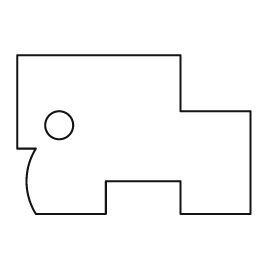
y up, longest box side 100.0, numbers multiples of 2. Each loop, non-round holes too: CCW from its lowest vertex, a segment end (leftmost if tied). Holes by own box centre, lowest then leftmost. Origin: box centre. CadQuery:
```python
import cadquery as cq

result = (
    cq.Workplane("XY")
    .moveTo(-42.0, -34.0)
    .lineTo(-12.0, -34.0)
    .lineTo(-12.0, -20.0)
    .lineTo(20.0, -20.0)
    .lineTo(20.0, -34.0)
    .lineTo(50.0, -34.0)
    .lineTo(50.0, 10.0)
    .lineTo(20.0, 10.0)
    .lineTo(20.0, 34.0)
    .lineTo(-50.0, 34.0)
    .lineTo(-50.0, -6.0)
    .lineTo(-42.0, -6.0)
    .threePointArc((-46.0, -20.0), (-42.0, -34.0))
    .close()
    .moveTo(-32.0, 4.0)
    .circle(6.0)
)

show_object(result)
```